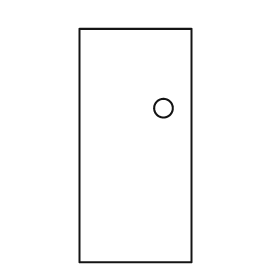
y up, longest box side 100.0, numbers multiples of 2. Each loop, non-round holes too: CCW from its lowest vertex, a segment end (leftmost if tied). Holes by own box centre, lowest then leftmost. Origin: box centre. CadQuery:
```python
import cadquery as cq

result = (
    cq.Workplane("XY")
    .moveTo(-24.0, -50.0)
    .lineTo(24.0, -50.0)
    .lineTo(24.0, 50.0)
    .lineTo(-24.0, 50.0)
    .close()
    .moveTo(12.0, 16.0)
    .circle(4.0)
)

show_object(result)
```